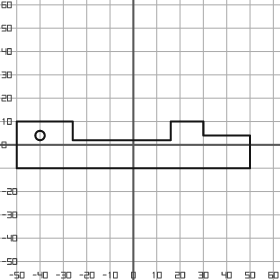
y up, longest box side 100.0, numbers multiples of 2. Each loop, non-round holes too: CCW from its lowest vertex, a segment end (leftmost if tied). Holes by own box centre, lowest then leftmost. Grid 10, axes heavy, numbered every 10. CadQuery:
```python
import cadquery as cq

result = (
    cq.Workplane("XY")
    .moveTo(-50.0, -10.0)
    .lineTo(50.0, -10.0)
    .lineTo(50.0, 4.0)
    .lineTo(30.0, 4.0)
    .lineTo(30.0, 10.0)
    .lineTo(16.0, 10.0)
    .lineTo(16.0, 2.0)
    .lineTo(-26.0, 2.0)
    .lineTo(-26.0, 10.0)
    .lineTo(-50.0, 10.0)
    .close()
    .moveTo(-40.0, 4.0)
    .circle(2.0)
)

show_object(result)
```